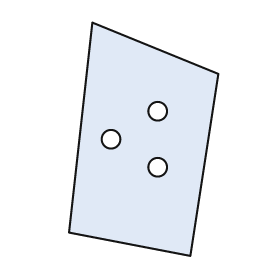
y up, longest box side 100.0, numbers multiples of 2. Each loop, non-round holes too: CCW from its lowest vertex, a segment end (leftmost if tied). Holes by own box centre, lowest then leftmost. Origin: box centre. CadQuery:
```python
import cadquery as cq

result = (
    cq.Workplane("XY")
    .moveTo(20.0, -50.0)
    .lineTo(32.0, 28.0)
    .lineTo(-22.0, 50.0)
    .lineTo(-32.0, -40.0)
    .close()
    .moveTo(6.0, -12.0)
    .circle(4.0)
    .moveTo(-14.0, 0.0)
    .circle(4.0)
    .moveTo(6.0, 12.0)
    .circle(4.0)
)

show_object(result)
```